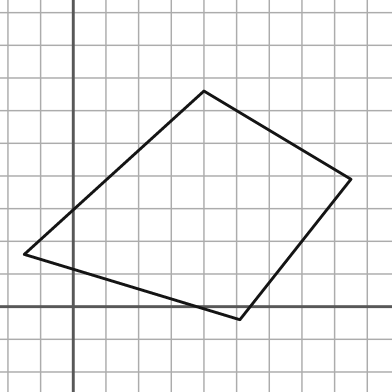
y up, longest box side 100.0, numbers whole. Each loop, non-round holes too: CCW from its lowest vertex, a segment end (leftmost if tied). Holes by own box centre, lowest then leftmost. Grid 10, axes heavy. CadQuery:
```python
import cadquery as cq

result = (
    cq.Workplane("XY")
    .moveTo(51.0, -4.0)
    .lineTo(85.0, 39.0)
    .lineTo(40.0, 66.0)
    .lineTo(-15.0, 16.0)
    .close()
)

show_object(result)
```